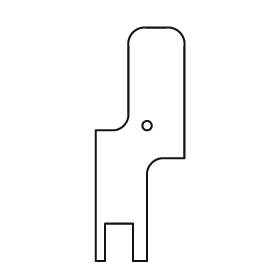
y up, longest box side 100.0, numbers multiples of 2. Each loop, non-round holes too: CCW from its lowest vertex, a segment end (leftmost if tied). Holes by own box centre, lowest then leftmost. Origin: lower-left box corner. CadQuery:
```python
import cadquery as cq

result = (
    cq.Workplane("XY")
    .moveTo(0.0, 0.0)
    .lineTo(4.0, 0.0)
    .lineTo(4.0, 16.0)
    .lineTo(16.0, 16.0)
    .lineTo(16.0, 0.0)
    .lineTo(22.0, 0.0)
    .lineTo(22.0, 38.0)
    .threePointArc((24.0, 42.0), (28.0, 44.0))
    .lineTo(38.0, 44.0)
    .lineTo(38.0, 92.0)
    .threePointArc((36.0, 98.0), (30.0, 100.0))
    .lineTo(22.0, 100.0)
    .threePointArc((16.0, 98.0), (14.0, 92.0))
    .lineTo(14.0, 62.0)
    .threePointArc((12.0, 58.0), (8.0, 56.0))
    .lineTo(0.0, 56.0)
    .close()
    .moveTo(22.0, 58.0)
    .circle(2.0)
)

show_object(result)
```